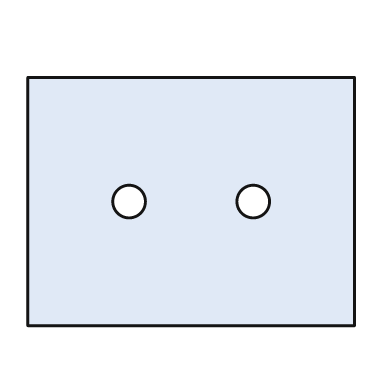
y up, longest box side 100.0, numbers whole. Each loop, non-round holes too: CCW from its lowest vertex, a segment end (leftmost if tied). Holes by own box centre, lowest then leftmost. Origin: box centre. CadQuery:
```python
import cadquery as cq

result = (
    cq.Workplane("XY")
    .moveTo(-50.0, -38.0)
    .lineTo(50.0, -38.0)
    .lineTo(50.0, 38.0)
    .lineTo(-50.0, 38.0)
    .close()
    .moveTo(-19.0, 0.0)
    .circle(5.0)
    .moveTo(19.0, 0.0)
    .circle(5.0)
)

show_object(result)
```